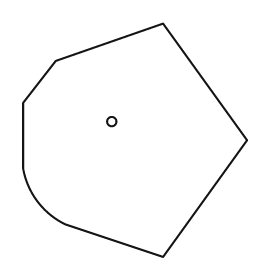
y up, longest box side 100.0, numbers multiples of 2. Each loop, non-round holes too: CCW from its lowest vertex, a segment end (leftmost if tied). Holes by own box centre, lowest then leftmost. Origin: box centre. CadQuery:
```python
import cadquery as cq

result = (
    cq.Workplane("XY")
    .moveTo(12.0, -50.0)
    .lineTo(48.0, 0.0)
    .lineTo(12.0, 50.0)
    .lineTo(-34.0, 34.0)
    .lineTo(-48.0, 16.0)
    .lineTo(-48.0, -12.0)
    .threePointArc((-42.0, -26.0), (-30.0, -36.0))
    .close()
    .moveTo(-10.0, 8.0)
    .circle(2.0)
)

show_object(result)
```